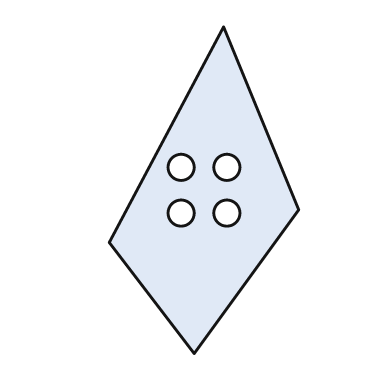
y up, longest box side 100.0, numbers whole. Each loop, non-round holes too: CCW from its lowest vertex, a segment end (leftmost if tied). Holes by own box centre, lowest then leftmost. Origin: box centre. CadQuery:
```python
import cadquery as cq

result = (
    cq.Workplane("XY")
    .moveTo(-3.0, -50.0)
    .lineTo(29.0, -6.0)
    .lineTo(6.0, 50.0)
    .lineTo(-29.0, -16.0)
    .close()
    .moveTo(-7.0, -7.0)
    .circle(4.0)
    .moveTo(7.0, -7.0)
    .circle(4.0)
    .moveTo(-7.0, 7.0)
    .circle(4.0)
    .moveTo(7.0, 7.0)
    .circle(4.0)
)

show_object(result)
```